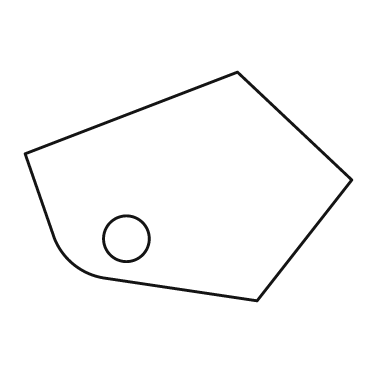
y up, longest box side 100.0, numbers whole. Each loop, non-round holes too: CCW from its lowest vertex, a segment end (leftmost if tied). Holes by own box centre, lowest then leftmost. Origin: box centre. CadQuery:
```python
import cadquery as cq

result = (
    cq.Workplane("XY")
    .moveTo(21.0, -35.0)
    .lineTo(50.0, 2.0)
    .lineTo(15.0, 35.0)
    .lineTo(-50.0, 10.0)
    .lineTo(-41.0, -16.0)
    .threePointArc((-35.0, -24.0), (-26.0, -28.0))
    .close()
    .moveTo(-19.0, -16.0)
    .circle(7.0)
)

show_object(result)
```